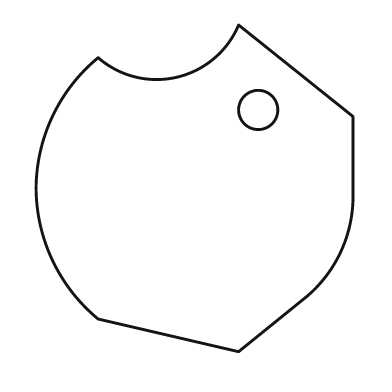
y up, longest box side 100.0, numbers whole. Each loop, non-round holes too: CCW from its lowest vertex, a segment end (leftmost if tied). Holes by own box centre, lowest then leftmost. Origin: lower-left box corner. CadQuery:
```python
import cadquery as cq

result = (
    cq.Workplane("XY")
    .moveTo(62.0, 0.0)
    .lineTo(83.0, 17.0)
    .threePointArc((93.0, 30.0), (97.0, 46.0))
    .lineTo(97.0, 72.0)
    .lineTo(62.0, 100.0)
    .threePointArc((43.0, 84.0), (19.0, 90.0))
    .threePointArc((5.0, 72.0), (0.0, 50.0))
    .threePointArc((5.0, 28.0), (19.0, 10.0))
    .close()
    .moveTo(68.0, 74.0)
    .circle(6.0)
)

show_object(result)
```